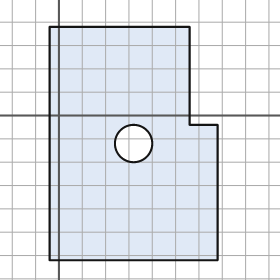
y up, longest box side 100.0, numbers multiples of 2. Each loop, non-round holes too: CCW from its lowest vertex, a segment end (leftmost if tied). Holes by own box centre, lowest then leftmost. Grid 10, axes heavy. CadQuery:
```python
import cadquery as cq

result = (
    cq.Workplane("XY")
    .moveTo(-4.0, -62.0)
    .lineTo(68.0, -62.0)
    .lineTo(68.0, -4.0)
    .lineTo(56.0, -4.0)
    .lineTo(56.0, 38.0)
    .lineTo(-4.0, 38.0)
    .close()
    .moveTo(32.0, -12.0)
    .circle(8.0)
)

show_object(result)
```